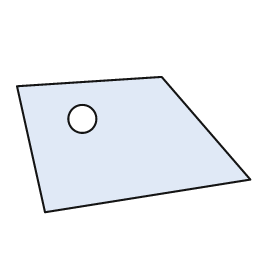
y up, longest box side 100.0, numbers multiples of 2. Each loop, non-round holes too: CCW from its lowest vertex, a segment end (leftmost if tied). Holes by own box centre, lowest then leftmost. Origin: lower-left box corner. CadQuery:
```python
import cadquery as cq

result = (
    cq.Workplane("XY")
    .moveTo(12.0, 0.0)
    .lineTo(100.0, 14.0)
    .lineTo(62.0, 58.0)
    .lineTo(0.0, 54.0)
    .close()
    .moveTo(28.0, 40.0)
    .circle(6.0)
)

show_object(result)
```